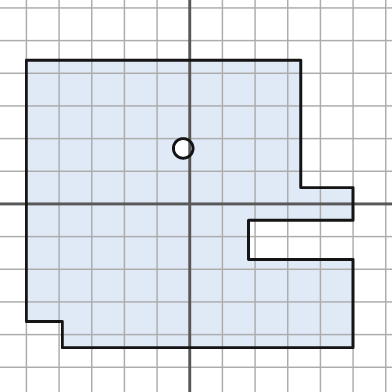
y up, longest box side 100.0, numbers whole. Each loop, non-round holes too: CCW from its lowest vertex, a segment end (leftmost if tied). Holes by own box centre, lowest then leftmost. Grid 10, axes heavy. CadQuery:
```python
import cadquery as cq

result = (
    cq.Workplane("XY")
    .moveTo(-39.0, -44.0)
    .lineTo(50.0, -44.0)
    .lineTo(50.0, -17.0)
    .lineTo(18.0, -17.0)
    .lineTo(18.0, -5.0)
    .lineTo(50.0, -5.0)
    .lineTo(50.0, 5.0)
    .lineTo(34.0, 5.0)
    .lineTo(34.0, 44.0)
    .lineTo(-50.0, 44.0)
    .lineTo(-50.0, -36.0)
    .lineTo(-39.0, -36.0)
    .close()
    .moveTo(-2.0, 17.0)
    .circle(3.0)
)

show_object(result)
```